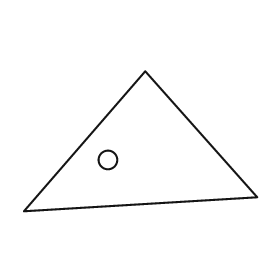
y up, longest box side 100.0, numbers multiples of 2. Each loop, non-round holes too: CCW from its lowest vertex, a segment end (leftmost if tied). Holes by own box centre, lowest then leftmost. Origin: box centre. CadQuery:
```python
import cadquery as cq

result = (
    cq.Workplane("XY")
    .moveTo(-50.0, -30.0)
    .lineTo(50.0, -24.0)
    .lineTo(2.0, 30.0)
    .close()
    .moveTo(-14.0, -8.0)
    .circle(4.0)
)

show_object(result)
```